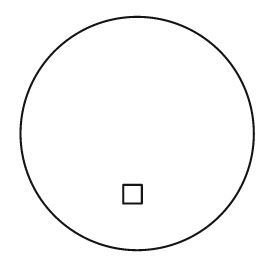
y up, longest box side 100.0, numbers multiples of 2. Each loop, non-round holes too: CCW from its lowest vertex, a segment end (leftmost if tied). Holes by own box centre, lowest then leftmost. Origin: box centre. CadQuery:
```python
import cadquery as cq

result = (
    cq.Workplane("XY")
    .moveTo(0.0, 0.0)
    .circle(50.0)
    .moveTo(-6.0, -30.0)
    .lineTo(2.0, -30.0)
    .lineTo(2.0, -22.0)
    .lineTo(-6.0, -22.0)
    .close()
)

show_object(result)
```